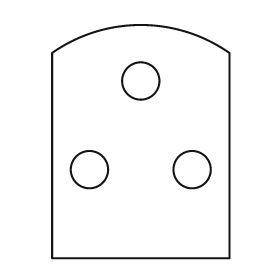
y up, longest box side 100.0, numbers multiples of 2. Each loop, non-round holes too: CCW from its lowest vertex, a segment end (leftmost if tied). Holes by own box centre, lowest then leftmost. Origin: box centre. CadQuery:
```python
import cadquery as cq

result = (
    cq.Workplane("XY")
    .moveTo(-38.0, -50.0)
    .lineTo(38.0, -50.0)
    .lineTo(38.0, 38.0)
    .threePointArc((0.0, 50.0), (-38.0, 38.0))
    .close()
    .moveTo(-22.0, -12.0)
    .circle(8.0)
    .moveTo(22.0, -12.0)
    .circle(8.0)
    .moveTo(0.0, 26.0)
    .circle(8.0)
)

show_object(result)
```